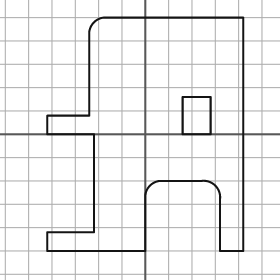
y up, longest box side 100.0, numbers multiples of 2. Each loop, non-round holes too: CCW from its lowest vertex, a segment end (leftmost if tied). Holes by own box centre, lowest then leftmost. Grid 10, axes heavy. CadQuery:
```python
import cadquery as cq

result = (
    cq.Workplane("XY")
    .moveTo(-42.0, -50.0)
    .lineTo(0.0, -50.0)
    .lineTo(0.0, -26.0)
    .threePointArc((2.0, -22.0), (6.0, -20.0))
    .lineTo(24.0, -20.0)
    .threePointArc((30.0, -22.0), (32.0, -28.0))
    .lineTo(32.0, -50.0)
    .lineTo(42.0, -50.0)
    .lineTo(42.0, 50.0)
    .lineTo(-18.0, 50.0)
    .threePointArc((-22.0, 48.0), (-24.0, 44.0))
    .lineTo(-24.0, 8.0)
    .lineTo(-42.0, 8.0)
    .lineTo(-42.0, 0.0)
    .lineTo(-22.0, 0.0)
    .lineTo(-22.0, -42.0)
    .lineTo(-42.0, -42.0)
    .close()
    .moveTo(16.0, 0.0)
    .lineTo(28.0, 0.0)
    .lineTo(28.0, 16.0)
    .lineTo(16.0, 16.0)
    .close()
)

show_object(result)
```